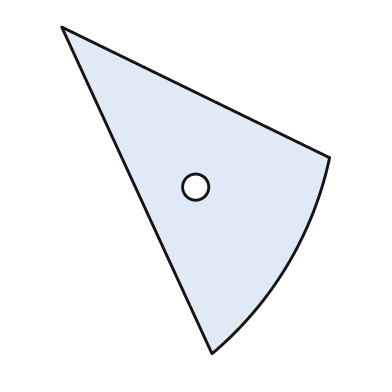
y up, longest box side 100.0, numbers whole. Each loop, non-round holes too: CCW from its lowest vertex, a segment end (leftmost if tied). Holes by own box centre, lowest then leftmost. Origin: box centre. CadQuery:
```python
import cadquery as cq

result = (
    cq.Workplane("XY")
    .moveTo(5.0, -50.0)
    .threePointArc((28.0, -23.0), (41.0, 10.0))
    .lineTo(-41.0, 50.0)
    .close()
    .moveTo(0.0, 1.0)
    .circle(4.0)
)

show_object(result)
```